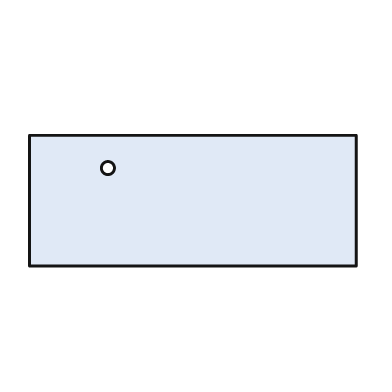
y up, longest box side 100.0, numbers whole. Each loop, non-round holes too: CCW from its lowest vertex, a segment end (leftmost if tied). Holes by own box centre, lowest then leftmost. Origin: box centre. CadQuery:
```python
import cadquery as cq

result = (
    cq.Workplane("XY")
    .moveTo(-50.0, -20.0)
    .lineTo(50.0, -20.0)
    .lineTo(50.0, 20.0)
    .lineTo(-50.0, 20.0)
    .close()
    .moveTo(-26.0, 10.0)
    .circle(2.0)
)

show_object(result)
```